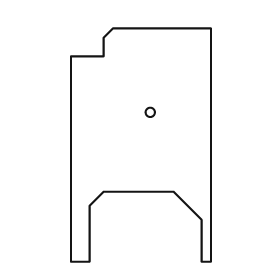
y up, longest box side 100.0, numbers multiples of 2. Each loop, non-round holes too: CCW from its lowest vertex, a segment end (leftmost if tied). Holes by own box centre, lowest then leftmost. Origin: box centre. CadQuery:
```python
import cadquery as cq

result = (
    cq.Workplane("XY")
    .moveTo(-30.0, -50.0)
    .lineTo(-22.0, -50.0)
    .lineTo(-22.0, -26.0)
    .lineTo(-16.0, -20.0)
    .lineTo(14.0, -20.0)
    .lineTo(26.0, -32.0)
    .lineTo(26.0, -50.0)
    .lineTo(30.0, -50.0)
    .lineTo(30.0, 50.0)
    .lineTo(-12.0, 50.0)
    .lineTo(-16.0, 46.0)
    .lineTo(-16.0, 38.0)
    .lineTo(-30.0, 38.0)
    .close()
    .moveTo(4.0, 14.0)
    .circle(2.0)
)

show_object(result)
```